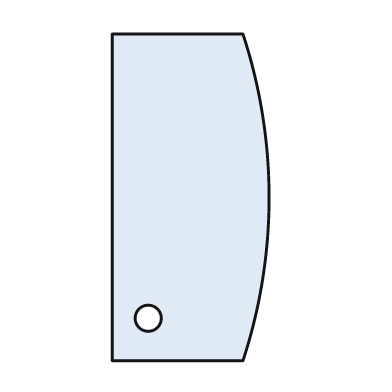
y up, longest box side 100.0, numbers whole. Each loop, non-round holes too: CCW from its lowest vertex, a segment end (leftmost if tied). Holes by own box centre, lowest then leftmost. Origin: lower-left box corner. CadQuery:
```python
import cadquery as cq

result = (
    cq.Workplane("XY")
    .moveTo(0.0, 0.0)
    .lineTo(40.0, 0.0)
    .threePointArc((48.0, 50.0), (40.0, 100.0))
    .lineTo(0.0, 100.0)
    .close()
    .moveTo(11.0, 13.0)
    .circle(4.0)
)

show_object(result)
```